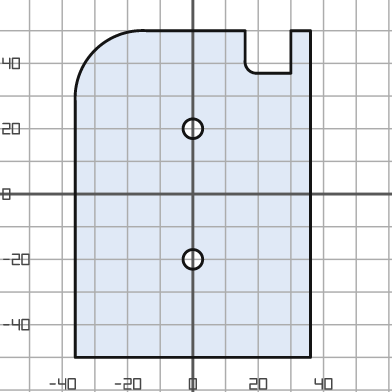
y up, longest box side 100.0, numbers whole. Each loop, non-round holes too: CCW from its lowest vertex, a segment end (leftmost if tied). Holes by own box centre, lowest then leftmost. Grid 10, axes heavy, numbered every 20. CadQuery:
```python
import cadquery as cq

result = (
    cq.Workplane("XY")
    .moveTo(-36.0, -50.0)
    .lineTo(36.0, -50.0)
    .lineTo(36.0, 50.0)
    .lineTo(30.0, 50.0)
    .lineTo(30.0, 37.0)
    .lineTo(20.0, 37.0)
    .threePointArc((17.0, 38.0), (16.0, 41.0))
    .lineTo(16.0, 50.0)
    .lineTo(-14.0, 50.0)
    .threePointArc((-30.0, 44.0), (-36.0, 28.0))
    .close()
    .moveTo(0.0, -20.0)
    .circle(3.0)
    .moveTo(0.0, 20.0)
    .circle(3.0)
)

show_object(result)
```